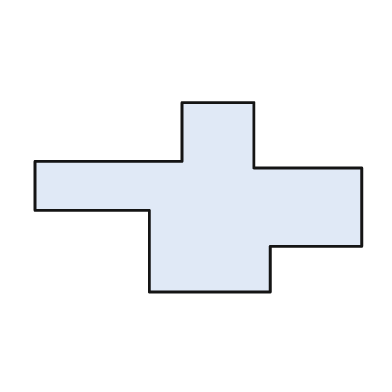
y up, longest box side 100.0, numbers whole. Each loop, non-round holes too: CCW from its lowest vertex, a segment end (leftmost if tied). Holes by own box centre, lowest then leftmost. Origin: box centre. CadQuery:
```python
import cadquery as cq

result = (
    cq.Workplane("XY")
    .moveTo(-15.0, -29.0)
    .lineTo(22.0, -29.0)
    .lineTo(22.0, -15.0)
    .lineTo(50.0, -15.0)
    .lineTo(50.0, 9.0)
    .lineTo(17.0, 9.0)
    .lineTo(17.0, 29.0)
    .lineTo(-5.0, 29.0)
    .lineTo(-5.0, 11.0)
    .lineTo(-50.0, 11.0)
    .lineTo(-50.0, -4.0)
    .lineTo(-15.0, -4.0)
    .close()
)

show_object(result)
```